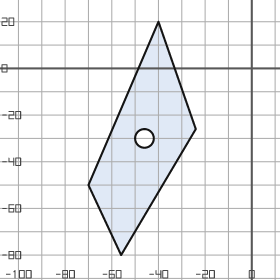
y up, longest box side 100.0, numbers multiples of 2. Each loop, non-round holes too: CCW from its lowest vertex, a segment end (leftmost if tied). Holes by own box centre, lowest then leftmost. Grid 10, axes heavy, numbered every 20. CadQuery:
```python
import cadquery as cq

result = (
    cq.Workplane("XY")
    .moveTo(-56.0, -80.0)
    .lineTo(-24.0, -26.0)
    .lineTo(-40.0, 20.0)
    .lineTo(-70.0, -50.0)
    .close()
    .moveTo(-46.0, -30.0)
    .circle(4.0)
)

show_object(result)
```